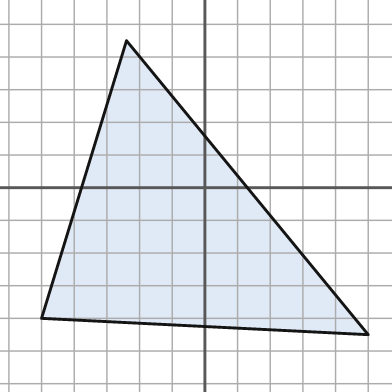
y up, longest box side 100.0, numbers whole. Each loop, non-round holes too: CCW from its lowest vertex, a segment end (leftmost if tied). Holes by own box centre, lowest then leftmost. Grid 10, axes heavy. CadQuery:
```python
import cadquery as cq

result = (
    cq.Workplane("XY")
    .moveTo(50.0, -45.0)
    .lineTo(-24.0, 45.0)
    .lineTo(-50.0, -40.0)
    .close()
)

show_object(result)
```